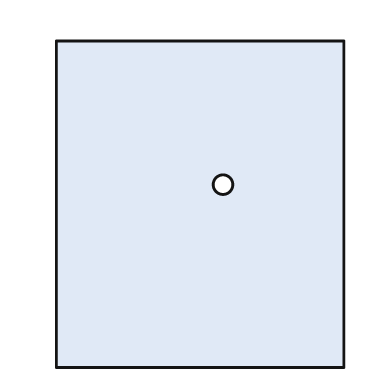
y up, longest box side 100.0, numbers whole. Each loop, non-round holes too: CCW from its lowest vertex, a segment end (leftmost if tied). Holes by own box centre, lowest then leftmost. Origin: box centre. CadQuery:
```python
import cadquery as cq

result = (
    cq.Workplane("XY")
    .moveTo(-44.0, -50.0)
    .lineTo(44.0, -50.0)
    .lineTo(44.0, 50.0)
    .lineTo(-44.0, 50.0)
    .close()
    .moveTo(7.0, 6.0)
    .circle(3.0)
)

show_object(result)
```